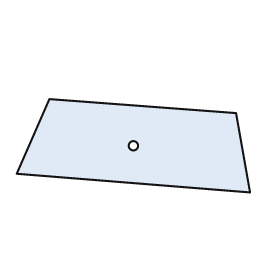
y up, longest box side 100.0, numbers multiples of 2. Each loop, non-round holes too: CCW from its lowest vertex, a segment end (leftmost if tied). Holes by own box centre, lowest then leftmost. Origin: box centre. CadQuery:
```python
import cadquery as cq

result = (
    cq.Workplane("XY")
    .moveTo(50.0, -20.0)
    .lineTo(44.0, 14.0)
    .lineTo(-36.0, 20.0)
    .lineTo(-50.0, -12.0)
    .close()
    .moveTo(0.0, 0.0)
    .circle(2.0)
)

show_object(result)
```